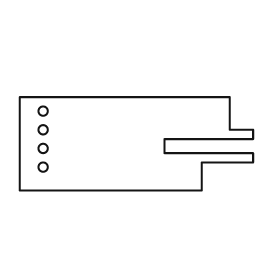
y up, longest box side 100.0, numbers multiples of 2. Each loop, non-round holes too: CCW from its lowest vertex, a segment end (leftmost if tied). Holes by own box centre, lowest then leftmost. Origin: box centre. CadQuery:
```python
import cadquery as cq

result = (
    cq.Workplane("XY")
    .moveTo(-50.0, -20.0)
    .lineTo(28.0, -20.0)
    .lineTo(28.0, -8.0)
    .lineTo(50.0, -8.0)
    .lineTo(50.0, -4.0)
    .lineTo(12.0, -4.0)
    .lineTo(12.0, 2.0)
    .lineTo(50.0, 2.0)
    .lineTo(50.0, 6.0)
    .lineTo(40.0, 6.0)
    .lineTo(40.0, 20.0)
    .lineTo(-50.0, 20.0)
    .close()
    .moveTo(-40.0, -10.0)
    .circle(2.0)
    .moveTo(-40.0, -2.0)
    .circle(2.0)
    .moveTo(-40.0, 6.0)
    .circle(2.0)
    .moveTo(-40.0, 14.0)
    .circle(2.0)
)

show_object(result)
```